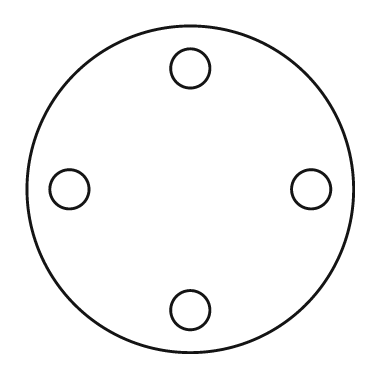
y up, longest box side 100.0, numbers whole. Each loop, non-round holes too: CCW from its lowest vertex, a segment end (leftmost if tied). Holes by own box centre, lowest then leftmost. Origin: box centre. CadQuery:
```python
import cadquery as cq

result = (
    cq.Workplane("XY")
    .moveTo(0.0, 0.0)
    .circle(50.0)
    .moveTo(0.0, -37.0)
    .circle(6.0)
    .moveTo(-37.0, 0.0)
    .circle(6.0)
    .moveTo(37.0, 0.0)
    .circle(6.0)
    .moveTo(0.0, 37.0)
    .circle(6.0)
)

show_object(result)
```